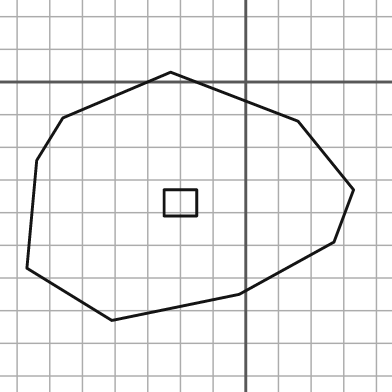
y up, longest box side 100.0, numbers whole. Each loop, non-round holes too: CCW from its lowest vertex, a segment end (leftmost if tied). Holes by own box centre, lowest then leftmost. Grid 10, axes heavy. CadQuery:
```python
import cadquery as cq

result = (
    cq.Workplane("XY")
    .moveTo(-41.0, -73.0)
    .lineTo(-2.0, -65.0)
    .lineTo(27.0, -49.0)
    .lineTo(33.0, -33.0)
    .lineTo(16.0, -12.0)
    .lineTo(-23.0, 3.0)
    .lineTo(-56.0, -11.0)
    .lineTo(-64.0, -24.0)
    .lineTo(-67.0, -57.0)
    .close()
    .moveTo(-25.0, -41.0)
    .lineTo(-15.0, -41.0)
    .lineTo(-15.0, -33.0)
    .lineTo(-25.0, -33.0)
    .close()
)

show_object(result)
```